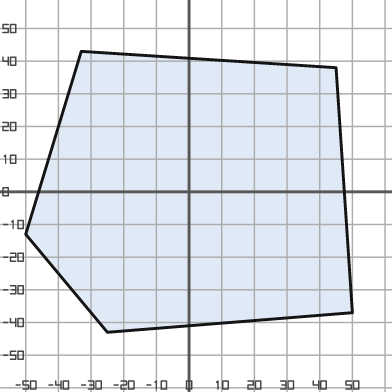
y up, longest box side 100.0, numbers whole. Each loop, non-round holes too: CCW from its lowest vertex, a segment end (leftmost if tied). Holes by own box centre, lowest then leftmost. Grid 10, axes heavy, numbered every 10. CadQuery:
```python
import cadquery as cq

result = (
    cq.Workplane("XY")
    .moveTo(-25.0, -43.0)
    .lineTo(50.0, -37.0)
    .lineTo(45.0, 38.0)
    .lineTo(-33.0, 43.0)
    .lineTo(-50.0, -13.0)
    .close()
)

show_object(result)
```